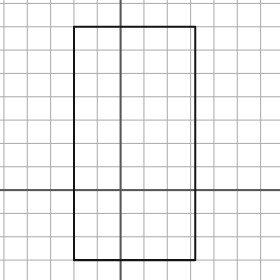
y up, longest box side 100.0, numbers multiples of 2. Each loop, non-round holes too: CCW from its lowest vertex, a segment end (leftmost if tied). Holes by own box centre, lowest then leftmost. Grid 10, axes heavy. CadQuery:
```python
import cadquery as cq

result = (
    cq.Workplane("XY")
    .moveTo(-20.0, -30.0)
    .lineTo(32.0, -30.0)
    .lineTo(32.0, 70.0)
    .lineTo(-20.0, 70.0)
    .close()
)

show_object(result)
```